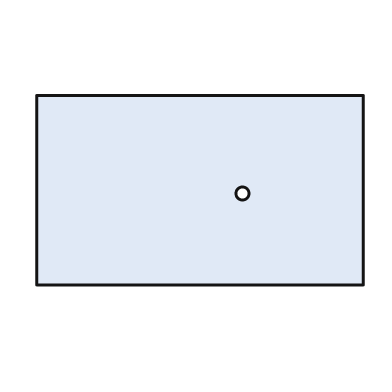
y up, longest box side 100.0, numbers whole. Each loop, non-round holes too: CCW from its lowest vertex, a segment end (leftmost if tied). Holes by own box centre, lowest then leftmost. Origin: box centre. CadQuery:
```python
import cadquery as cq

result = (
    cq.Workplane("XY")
    .moveTo(-50.0, -29.0)
    .lineTo(50.0, -29.0)
    .lineTo(50.0, 29.0)
    .lineTo(-50.0, 29.0)
    .close()
    .moveTo(13.0, -1.0)
    .circle(2.0)
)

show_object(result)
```